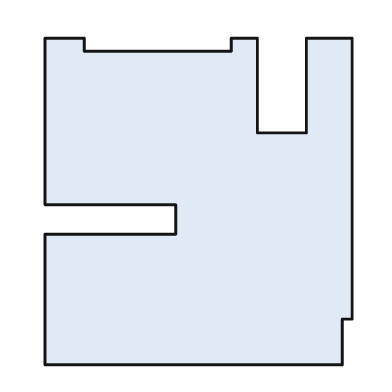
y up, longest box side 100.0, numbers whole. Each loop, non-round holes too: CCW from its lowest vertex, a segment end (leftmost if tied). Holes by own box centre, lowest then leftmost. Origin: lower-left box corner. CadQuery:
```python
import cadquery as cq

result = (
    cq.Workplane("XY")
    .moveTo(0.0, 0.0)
    .lineTo(91.0, 0.0)
    .lineTo(91.0, 14.0)
    .lineTo(94.0, 14.0)
    .lineTo(94.0, 100.0)
    .lineTo(80.0, 100.0)
    .lineTo(80.0, 71.0)
    .lineTo(65.0, 71.0)
    .lineTo(65.0, 100.0)
    .lineTo(57.0, 100.0)
    .lineTo(57.0, 96.0)
    .lineTo(12.0, 96.0)
    .lineTo(12.0, 100.0)
    .lineTo(0.0, 100.0)
    .lineTo(0.0, 49.0)
    .lineTo(40.0, 49.0)
    .lineTo(40.0, 40.0)
    .lineTo(0.0, 40.0)
    .close()
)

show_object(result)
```